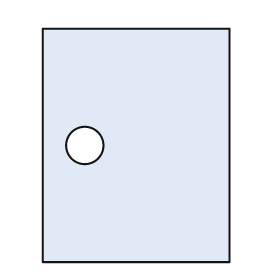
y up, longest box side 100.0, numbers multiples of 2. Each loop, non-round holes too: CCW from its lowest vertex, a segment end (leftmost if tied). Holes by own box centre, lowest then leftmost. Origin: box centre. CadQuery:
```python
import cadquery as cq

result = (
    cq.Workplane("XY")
    .moveTo(-40.0, -50.0)
    .lineTo(40.0, -50.0)
    .lineTo(40.0, 50.0)
    .lineTo(-40.0, 50.0)
    .close()
    .moveTo(-22.0, 0.0)
    .circle(8.0)
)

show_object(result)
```